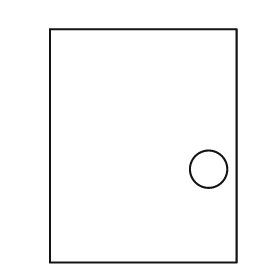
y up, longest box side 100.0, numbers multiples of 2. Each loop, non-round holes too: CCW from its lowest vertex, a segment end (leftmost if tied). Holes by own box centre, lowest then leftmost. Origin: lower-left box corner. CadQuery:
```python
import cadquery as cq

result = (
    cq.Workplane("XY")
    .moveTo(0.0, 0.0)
    .lineTo(80.0, 0.0)
    .lineTo(80.0, 100.0)
    .lineTo(0.0, 100.0)
    .close()
    .moveTo(68.0, 40.0)
    .circle(8.0)
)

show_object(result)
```